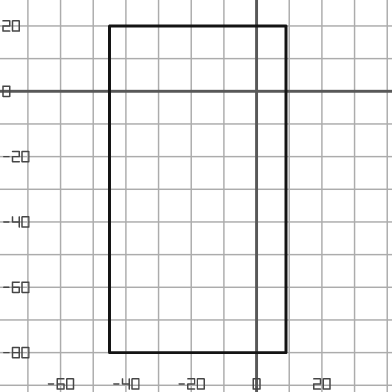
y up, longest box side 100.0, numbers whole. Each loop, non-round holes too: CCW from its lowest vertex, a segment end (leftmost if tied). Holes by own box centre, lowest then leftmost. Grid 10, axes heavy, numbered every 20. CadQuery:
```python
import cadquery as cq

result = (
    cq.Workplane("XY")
    .moveTo(-45.0, -80.0)
    .lineTo(9.0, -80.0)
    .lineTo(9.0, 20.0)
    .lineTo(-45.0, 20.0)
    .close()
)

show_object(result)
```